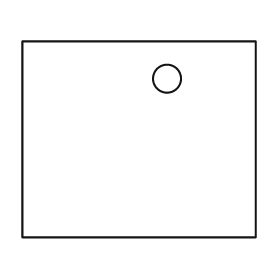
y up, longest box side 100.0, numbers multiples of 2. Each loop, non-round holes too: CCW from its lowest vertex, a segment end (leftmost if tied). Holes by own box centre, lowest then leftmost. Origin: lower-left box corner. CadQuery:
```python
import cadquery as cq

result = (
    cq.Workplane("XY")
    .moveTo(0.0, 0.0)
    .lineTo(100.0, 0.0)
    .lineTo(100.0, 84.0)
    .lineTo(0.0, 84.0)
    .close()
    .moveTo(62.0, 68.0)
    .circle(6.0)
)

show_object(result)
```